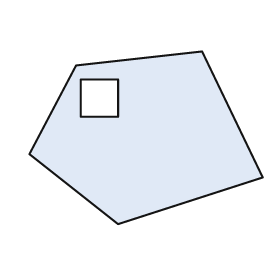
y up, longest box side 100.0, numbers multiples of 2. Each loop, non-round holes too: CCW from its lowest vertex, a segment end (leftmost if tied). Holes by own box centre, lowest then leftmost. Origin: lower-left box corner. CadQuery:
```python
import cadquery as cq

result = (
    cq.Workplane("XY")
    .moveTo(38.0, 0.0)
    .lineTo(100.0, 20.0)
    .lineTo(74.0, 74.0)
    .lineTo(20.0, 68.0)
    .lineTo(0.0, 30.0)
    .close()
    .moveTo(22.0, 46.0)
    .lineTo(38.0, 46.0)
    .lineTo(38.0, 62.0)
    .lineTo(22.0, 62.0)
    .close()
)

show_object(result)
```